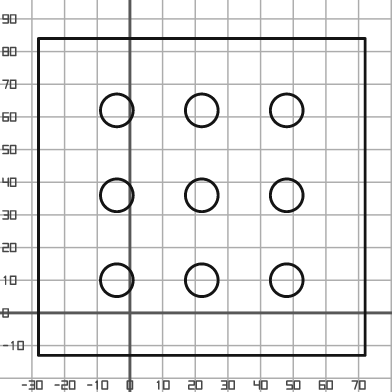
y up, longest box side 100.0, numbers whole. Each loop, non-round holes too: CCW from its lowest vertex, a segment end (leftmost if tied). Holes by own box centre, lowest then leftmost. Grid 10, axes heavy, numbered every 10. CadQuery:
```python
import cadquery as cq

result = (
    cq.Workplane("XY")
    .moveTo(-28.0, -13.0)
    .lineTo(72.0, -13.0)
    .lineTo(72.0, 84.0)
    .lineTo(-28.0, 84.0)
    .close()
    .moveTo(-4.0, 10.0)
    .circle(5.0)
    .moveTo(22.0, 10.0)
    .circle(5.0)
    .moveTo(48.0, 10.0)
    .circle(5.0)
    .moveTo(-4.0, 36.0)
    .circle(5.0)
    .moveTo(22.0, 36.0)
    .circle(5.0)
    .moveTo(48.0, 36.0)
    .circle(5.0)
    .moveTo(-4.0, 62.0)
    .circle(5.0)
    .moveTo(22.0, 62.0)
    .circle(5.0)
    .moveTo(48.0, 62.0)
    .circle(5.0)
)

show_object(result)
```